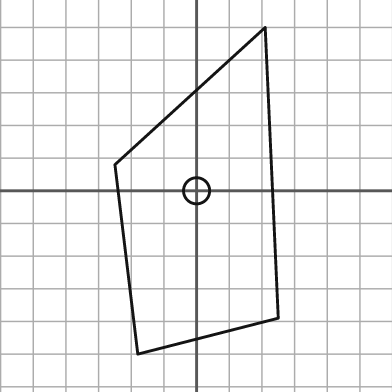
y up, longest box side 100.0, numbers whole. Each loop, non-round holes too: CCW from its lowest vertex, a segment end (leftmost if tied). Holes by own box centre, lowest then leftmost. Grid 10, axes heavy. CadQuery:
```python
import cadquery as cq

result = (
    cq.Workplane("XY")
    .moveTo(-18.0, -50.0)
    .lineTo(25.0, -39.0)
    .lineTo(21.0, 50.0)
    .lineTo(-25.0, 8.0)
    .close()
    .moveTo(0.0, 0.0)
    .circle(4.0)
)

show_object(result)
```